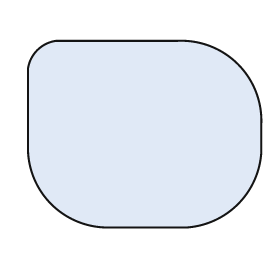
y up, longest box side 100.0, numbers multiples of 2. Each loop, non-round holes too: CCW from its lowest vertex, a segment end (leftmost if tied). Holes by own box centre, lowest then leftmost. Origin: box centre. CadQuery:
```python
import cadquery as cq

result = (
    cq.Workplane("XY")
    .moveTo(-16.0, -40.0)
    .lineTo(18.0, -40.0)
    .threePointArc((40.0, -30.0), (50.0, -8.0))
    .lineTo(50.0, 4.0)
    .threePointArc((40.0, 30.0), (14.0, 40.0))
    .lineTo(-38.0, 40.0)
    .threePointArc((-46.0, 36.0), (-50.0, 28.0))
    .lineTo(-50.0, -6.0)
    .threePointArc((-40.0, -30.0), (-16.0, -40.0))
    .close()
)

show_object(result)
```